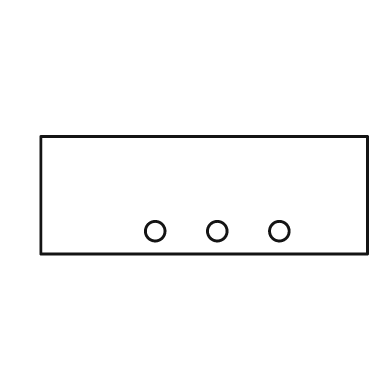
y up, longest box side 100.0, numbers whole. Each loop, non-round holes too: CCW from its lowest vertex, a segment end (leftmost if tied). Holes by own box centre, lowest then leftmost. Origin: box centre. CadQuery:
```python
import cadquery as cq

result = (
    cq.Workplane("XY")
    .moveTo(-50.0, -18.0)
    .lineTo(50.0, -18.0)
    .lineTo(50.0, 18.0)
    .lineTo(-50.0, 18.0)
    .close()
    .moveTo(-15.0, -11.0)
    .circle(3.0)
    .moveTo(4.0, -11.0)
    .circle(3.0)
    .moveTo(23.0, -11.0)
    .circle(3.0)
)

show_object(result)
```